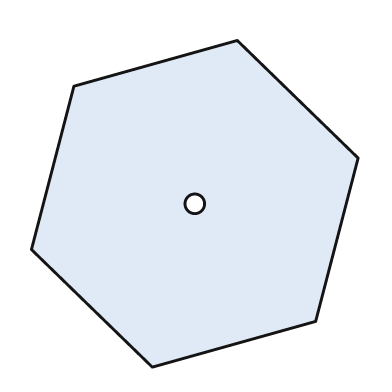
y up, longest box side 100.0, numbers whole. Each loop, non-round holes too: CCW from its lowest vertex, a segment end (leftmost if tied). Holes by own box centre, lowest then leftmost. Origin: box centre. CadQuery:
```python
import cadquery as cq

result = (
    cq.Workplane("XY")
    .moveTo(-13.0, -50.0)
    .lineTo(37.0, -36.0)
    .lineTo(50.0, 14.0)
    .lineTo(13.0, 50.0)
    .lineTo(-37.0, 36.0)
    .lineTo(-50.0, -14.0)
    .close()
    .moveTo(0.0, 0.0)
    .circle(3.0)
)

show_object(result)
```